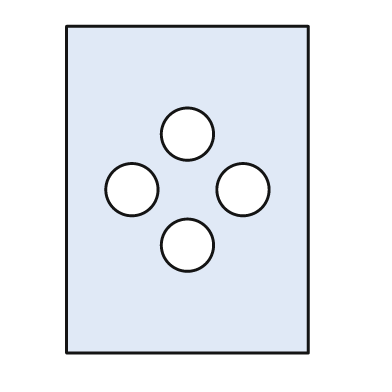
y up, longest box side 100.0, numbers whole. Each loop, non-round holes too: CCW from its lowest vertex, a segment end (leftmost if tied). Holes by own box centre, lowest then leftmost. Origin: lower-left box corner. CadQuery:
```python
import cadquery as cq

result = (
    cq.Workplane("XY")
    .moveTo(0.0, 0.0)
    .lineTo(74.0, 0.0)
    .lineTo(74.0, 100.0)
    .lineTo(0.0, 100.0)
    .close()
    .moveTo(37.0, 33.0)
    .circle(8.0)
    .moveTo(20.0, 50.0)
    .circle(8.0)
    .moveTo(54.0, 50.0)
    .circle(8.0)
    .moveTo(37.0, 67.0)
    .circle(8.0)
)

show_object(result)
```